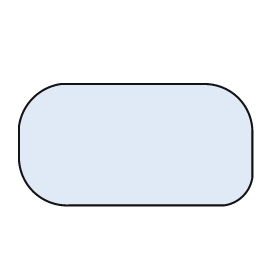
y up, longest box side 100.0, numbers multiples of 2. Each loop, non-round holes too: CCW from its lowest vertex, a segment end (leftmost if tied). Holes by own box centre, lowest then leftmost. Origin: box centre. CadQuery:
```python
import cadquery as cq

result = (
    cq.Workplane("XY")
    .moveTo(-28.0, -26.0)
    .lineTo(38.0, -26.0)
    .threePointArc((46.0, -22.0), (50.0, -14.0))
    .lineTo(50.0, 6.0)
    .threePointArc((44.0, 20.0), (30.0, 26.0))
    .lineTo(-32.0, 26.0)
    .threePointArc((-44.0, 20.0), (-50.0, 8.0))
    .lineTo(-50.0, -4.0)
    .threePointArc((-44.0, -20.0), (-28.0, -26.0))
    .close()
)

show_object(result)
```